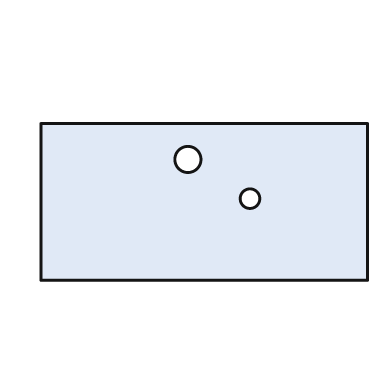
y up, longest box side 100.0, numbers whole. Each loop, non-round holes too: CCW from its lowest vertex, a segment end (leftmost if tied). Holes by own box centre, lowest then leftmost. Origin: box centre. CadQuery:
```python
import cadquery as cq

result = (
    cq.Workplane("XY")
    .moveTo(-50.0, -24.0)
    .lineTo(50.0, -24.0)
    .lineTo(50.0, 24.0)
    .lineTo(-50.0, 24.0)
    .close()
    .moveTo(14.0, 1.0)
    .circle(3.0)
    .moveTo(-5.0, 13.0)
    .circle(4.0)
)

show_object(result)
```